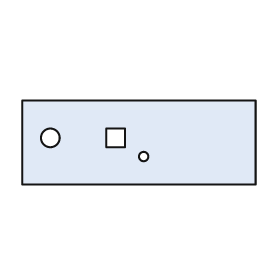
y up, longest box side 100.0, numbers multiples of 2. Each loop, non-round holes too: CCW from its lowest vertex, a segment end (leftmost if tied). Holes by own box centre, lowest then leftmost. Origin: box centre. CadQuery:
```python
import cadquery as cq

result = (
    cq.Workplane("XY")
    .moveTo(-50.0, -18.0)
    .lineTo(50.0, -18.0)
    .lineTo(50.0, 18.0)
    .lineTo(-50.0, 18.0)
    .close()
    .moveTo(2.0, -6.0)
    .circle(2.0)
    .moveTo(-38.0, 2.0)
    .circle(4.0)
    .moveTo(-14.0, -2.0)
    .lineTo(-6.0, -2.0)
    .lineTo(-6.0, 6.0)
    .lineTo(-14.0, 6.0)
    .close()
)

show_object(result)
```